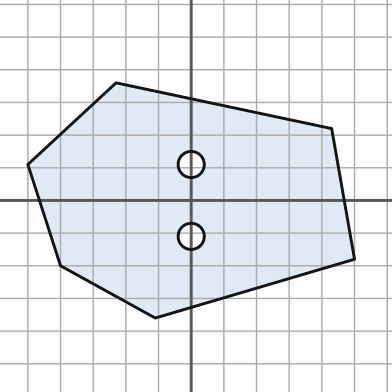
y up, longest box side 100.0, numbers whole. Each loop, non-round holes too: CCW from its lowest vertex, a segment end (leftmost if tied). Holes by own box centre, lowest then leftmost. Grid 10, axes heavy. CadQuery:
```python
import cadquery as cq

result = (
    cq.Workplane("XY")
    .moveTo(-11.0, -36.0)
    .lineTo(50.0, -18.0)
    .lineTo(43.0, 22.0)
    .lineTo(-23.0, 36.0)
    .lineTo(-50.0, 11.0)
    .lineTo(-40.0, -20.0)
    .close()
    .moveTo(0.0, -11.0)
    .circle(4.0)
    .moveTo(0.0, 11.0)
    .circle(4.0)
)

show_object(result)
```